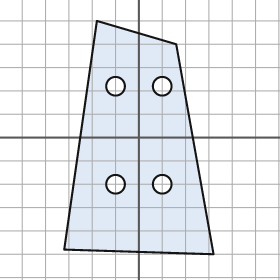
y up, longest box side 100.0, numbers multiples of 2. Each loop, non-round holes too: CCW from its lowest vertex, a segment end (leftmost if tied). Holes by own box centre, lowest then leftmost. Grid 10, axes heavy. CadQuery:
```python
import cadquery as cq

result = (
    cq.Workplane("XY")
    .moveTo(32.0, -50.0)
    .lineTo(16.0, 40.0)
    .lineTo(-18.0, 50.0)
    .lineTo(-32.0, -48.0)
    .close()
    .moveTo(-10.0, -20.0)
    .circle(4.0)
    .moveTo(10.0, -20.0)
    .circle(4.0)
    .moveTo(-10.0, 22.0)
    .circle(4.0)
    .moveTo(10.0, 22.0)
    .circle(4.0)
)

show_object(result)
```